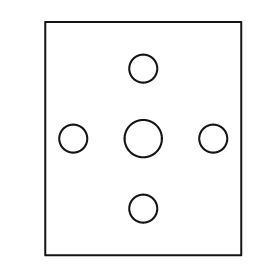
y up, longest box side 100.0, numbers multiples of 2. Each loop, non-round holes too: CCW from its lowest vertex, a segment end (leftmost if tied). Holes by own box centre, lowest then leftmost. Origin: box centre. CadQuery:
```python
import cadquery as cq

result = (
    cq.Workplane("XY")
    .moveTo(-42.0, -50.0)
    .lineTo(42.0, -50.0)
    .lineTo(42.0, 50.0)
    .lineTo(-42.0, 50.0)
    .close()
    .moveTo(0.0, -30.0)
    .circle(6.0)
    .moveTo(-30.0, 0.0)
    .circle(6.0)
    .moveTo(0.0, 0.0)
    .circle(8.0)
    .moveTo(30.0, 0.0)
    .circle(6.0)
    .moveTo(0.0, 30.0)
    .circle(6.0)
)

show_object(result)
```